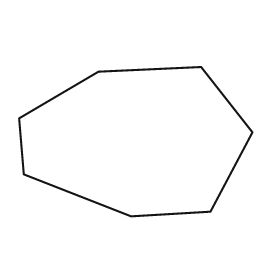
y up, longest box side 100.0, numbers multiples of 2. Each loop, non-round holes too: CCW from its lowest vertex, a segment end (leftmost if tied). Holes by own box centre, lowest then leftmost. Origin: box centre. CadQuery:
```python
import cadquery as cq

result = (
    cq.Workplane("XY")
    .moveTo(-2.0, -32.0)
    .lineTo(32.0, -30.0)
    .lineTo(50.0, 4.0)
    .lineTo(28.0, 32.0)
    .lineTo(-16.0, 30.0)
    .lineTo(-50.0, 10.0)
    .lineTo(-48.0, -14.0)
    .close()
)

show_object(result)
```